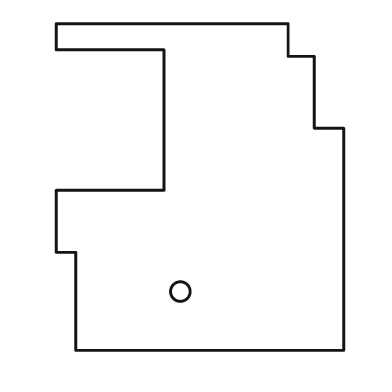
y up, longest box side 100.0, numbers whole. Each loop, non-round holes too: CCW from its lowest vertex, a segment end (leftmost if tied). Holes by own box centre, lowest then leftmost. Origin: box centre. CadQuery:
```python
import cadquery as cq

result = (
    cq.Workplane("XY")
    .moveTo(-38.0, -50.0)
    .lineTo(44.0, -50.0)
    .lineTo(44.0, 18.0)
    .lineTo(35.0, 18.0)
    .lineTo(35.0, 40.0)
    .lineTo(27.0, 40.0)
    .lineTo(27.0, 50.0)
    .lineTo(-44.0, 50.0)
    .lineTo(-44.0, 42.0)
    .lineTo(-11.0, 42.0)
    .lineTo(-11.0, -1.0)
    .lineTo(-44.0, -1.0)
    .lineTo(-44.0, -20.0)
    .lineTo(-38.0, -20.0)
    .close()
    .moveTo(-6.0, -32.0)
    .circle(3.0)
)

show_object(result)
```